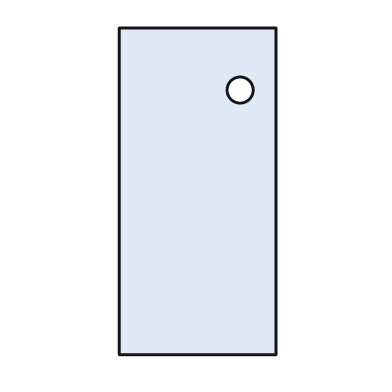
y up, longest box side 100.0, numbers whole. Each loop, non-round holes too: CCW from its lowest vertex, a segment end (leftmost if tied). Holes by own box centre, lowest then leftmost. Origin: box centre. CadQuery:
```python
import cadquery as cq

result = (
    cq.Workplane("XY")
    .moveTo(-24.0, -50.0)
    .lineTo(24.0, -50.0)
    .lineTo(24.0, 50.0)
    .lineTo(-24.0, 50.0)
    .close()
    .moveTo(13.0, 31.0)
    .circle(4.0)
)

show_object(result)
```